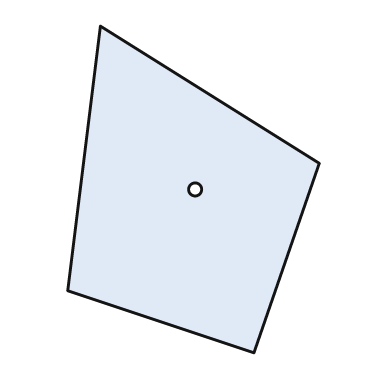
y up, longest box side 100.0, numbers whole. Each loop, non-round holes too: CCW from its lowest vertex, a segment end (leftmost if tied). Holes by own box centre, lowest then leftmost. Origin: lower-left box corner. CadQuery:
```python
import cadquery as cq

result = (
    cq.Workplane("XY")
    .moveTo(57.0, 0.0)
    .lineTo(77.0, 58.0)
    .lineTo(10.0, 100.0)
    .lineTo(0.0, 19.0)
    .close()
    .moveTo(39.0, 50.0)
    .circle(2.0)
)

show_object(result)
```